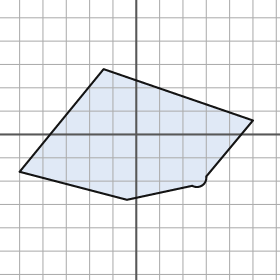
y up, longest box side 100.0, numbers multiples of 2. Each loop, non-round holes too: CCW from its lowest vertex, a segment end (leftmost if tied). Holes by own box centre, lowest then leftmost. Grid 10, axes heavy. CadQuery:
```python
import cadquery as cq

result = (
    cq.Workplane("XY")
    .moveTo(-4.0, -28.0)
    .lineTo(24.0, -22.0)
    .threePointArc((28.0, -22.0), (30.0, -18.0))
    .lineTo(50.0, 6.0)
    .lineTo(-14.0, 28.0)
    .lineTo(-50.0, -16.0)
    .close()
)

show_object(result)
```